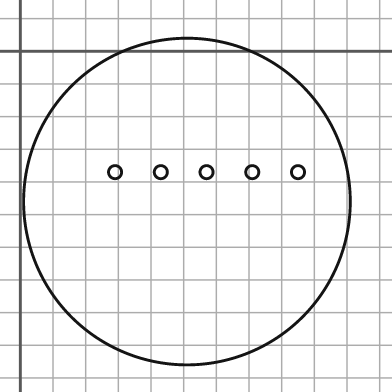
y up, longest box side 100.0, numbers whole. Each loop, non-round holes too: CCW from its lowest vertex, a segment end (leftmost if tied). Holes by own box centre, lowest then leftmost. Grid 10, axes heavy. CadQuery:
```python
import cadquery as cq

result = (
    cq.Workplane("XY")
    .moveTo(51.0, -46.0)
    .circle(50.0)
    .moveTo(29.0, -37.0)
    .circle(2.0)
    .moveTo(43.0, -37.0)
    .circle(2.0)
    .moveTo(57.0, -37.0)
    .circle(2.0)
    .moveTo(71.0, -37.0)
    .circle(2.0)
    .moveTo(85.0, -37.0)
    .circle(2.0)
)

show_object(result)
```